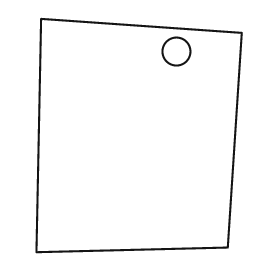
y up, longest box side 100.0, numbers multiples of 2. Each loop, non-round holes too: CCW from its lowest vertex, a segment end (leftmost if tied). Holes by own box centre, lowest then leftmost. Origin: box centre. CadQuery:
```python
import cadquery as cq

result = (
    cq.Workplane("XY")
    .moveTo(-44.0, -50.0)
    .lineTo(38.0, -48.0)
    .lineTo(44.0, 44.0)
    .lineTo(-42.0, 50.0)
    .close()
    .moveTo(16.0, 36.0)
    .circle(6.0)
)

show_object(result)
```